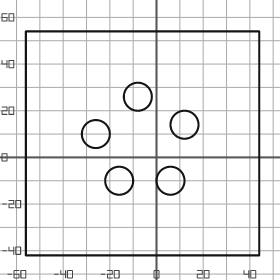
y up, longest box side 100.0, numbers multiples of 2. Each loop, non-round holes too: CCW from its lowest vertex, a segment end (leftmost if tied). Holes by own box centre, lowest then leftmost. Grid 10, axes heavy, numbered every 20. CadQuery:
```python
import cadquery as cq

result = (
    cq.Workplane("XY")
    .moveTo(-56.0, -42.0)
    .lineTo(44.0, -42.0)
    .lineTo(44.0, 54.0)
    .lineTo(-56.0, 54.0)
    .close()
    .moveTo(-16.0, -10.0)
    .circle(6.0)
    .moveTo(6.0, -10.0)
    .circle(6.0)
    .moveTo(-26.0, 10.0)
    .circle(6.0)
    .moveTo(12.0, 14.0)
    .circle(6.0)
    .moveTo(-8.0, 26.0)
    .circle(6.0)
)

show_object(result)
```